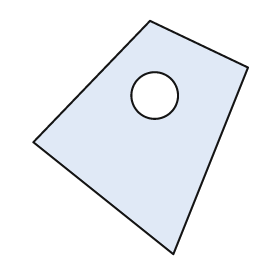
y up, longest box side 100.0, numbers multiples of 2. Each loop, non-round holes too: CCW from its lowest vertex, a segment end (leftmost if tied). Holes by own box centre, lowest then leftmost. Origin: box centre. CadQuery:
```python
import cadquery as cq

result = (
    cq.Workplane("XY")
    .moveTo(14.0, -50.0)
    .lineTo(46.0, 30.0)
    .lineTo(4.0, 50.0)
    .lineTo(-46.0, -2.0)
    .close()
    .moveTo(6.0, 18.0)
    .circle(10.0)
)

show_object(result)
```